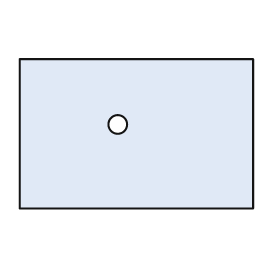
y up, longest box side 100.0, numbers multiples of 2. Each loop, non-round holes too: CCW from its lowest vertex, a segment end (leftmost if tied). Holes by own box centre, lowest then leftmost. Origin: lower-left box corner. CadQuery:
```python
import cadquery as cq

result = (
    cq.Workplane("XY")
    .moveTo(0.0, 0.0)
    .lineTo(100.0, 0.0)
    .lineTo(100.0, 64.0)
    .lineTo(0.0, 64.0)
    .close()
    .moveTo(42.0, 36.0)
    .circle(4.0)
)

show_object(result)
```